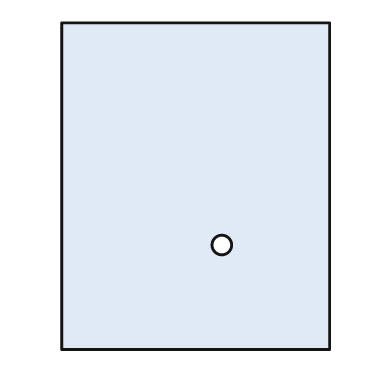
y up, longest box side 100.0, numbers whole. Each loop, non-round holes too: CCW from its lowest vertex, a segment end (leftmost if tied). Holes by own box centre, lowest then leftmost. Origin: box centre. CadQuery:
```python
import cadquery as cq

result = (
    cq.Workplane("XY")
    .moveTo(-41.0, -50.0)
    .lineTo(41.0, -50.0)
    .lineTo(41.0, 50.0)
    .lineTo(-41.0, 50.0)
    .close()
    .moveTo(8.0, -18.0)
    .circle(3.0)
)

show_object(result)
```